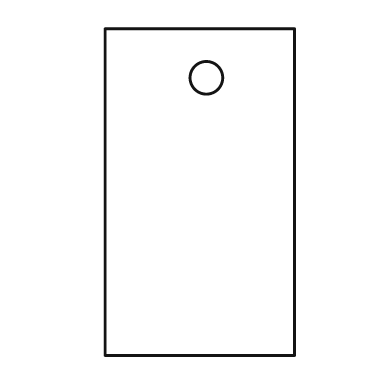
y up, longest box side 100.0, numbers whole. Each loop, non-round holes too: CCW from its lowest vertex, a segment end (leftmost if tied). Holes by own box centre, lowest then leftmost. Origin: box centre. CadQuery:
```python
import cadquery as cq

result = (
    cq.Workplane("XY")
    .moveTo(-29.0, -50.0)
    .lineTo(29.0, -50.0)
    .lineTo(29.0, 50.0)
    .lineTo(-29.0, 50.0)
    .close()
    .moveTo(2.0, 35.0)
    .circle(5.0)
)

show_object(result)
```